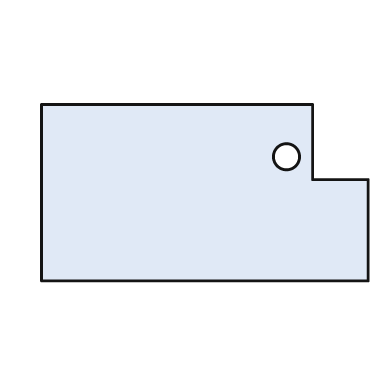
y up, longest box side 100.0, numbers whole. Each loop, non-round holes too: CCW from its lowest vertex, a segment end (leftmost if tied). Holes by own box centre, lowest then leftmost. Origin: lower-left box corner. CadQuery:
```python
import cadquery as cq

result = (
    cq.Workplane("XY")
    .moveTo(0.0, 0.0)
    .lineTo(100.0, 0.0)
    .lineTo(100.0, 31.0)
    .lineTo(83.0, 31.0)
    .lineTo(83.0, 54.0)
    .lineTo(0.0, 54.0)
    .close()
    .moveTo(75.0, 38.0)
    .circle(4.0)
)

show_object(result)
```